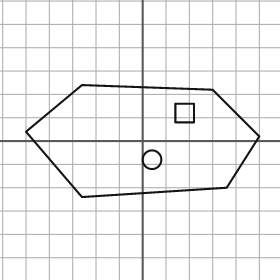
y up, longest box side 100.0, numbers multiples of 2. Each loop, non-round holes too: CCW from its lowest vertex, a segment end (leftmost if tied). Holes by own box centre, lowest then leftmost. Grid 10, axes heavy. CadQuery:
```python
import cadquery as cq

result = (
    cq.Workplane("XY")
    .moveTo(-26.0, -24.0)
    .lineTo(36.0, -20.0)
    .lineTo(50.0, 2.0)
    .lineTo(30.0, 22.0)
    .lineTo(-26.0, 24.0)
    .lineTo(-50.0, 4.0)
    .close()
    .moveTo(4.0, -8.0)
    .circle(4.0)
    .moveTo(14.0, 8.0)
    .lineTo(22.0, 8.0)
    .lineTo(22.0, 16.0)
    .lineTo(14.0, 16.0)
    .close()
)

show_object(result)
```